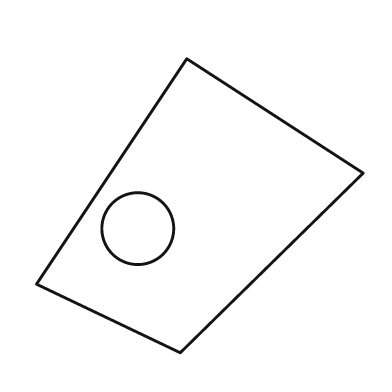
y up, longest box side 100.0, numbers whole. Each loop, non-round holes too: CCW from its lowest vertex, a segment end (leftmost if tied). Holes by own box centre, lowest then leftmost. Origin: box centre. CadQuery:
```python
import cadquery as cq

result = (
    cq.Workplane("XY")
    .moveTo(-6.0, -45.0)
    .lineTo(50.0, 10.0)
    .lineTo(-4.0, 45.0)
    .lineTo(-50.0, -24.0)
    .close()
    .moveTo(-19.0, -7.0)
    .circle(11.0)
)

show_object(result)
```